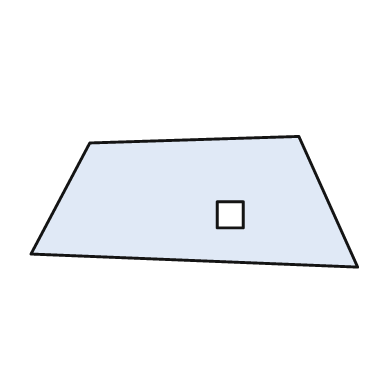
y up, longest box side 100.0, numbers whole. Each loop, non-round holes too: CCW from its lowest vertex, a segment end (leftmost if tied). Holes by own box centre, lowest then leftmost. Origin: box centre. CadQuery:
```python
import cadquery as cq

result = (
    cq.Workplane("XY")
    .moveTo(50.0, -20.0)
    .lineTo(32.0, 20.0)
    .lineTo(-32.0, 18.0)
    .lineTo(-50.0, -16.0)
    .close()
    .moveTo(7.0, -8.0)
    .lineTo(15.0, -8.0)
    .lineTo(15.0, 0.0)
    .lineTo(7.0, 0.0)
    .close()
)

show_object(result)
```